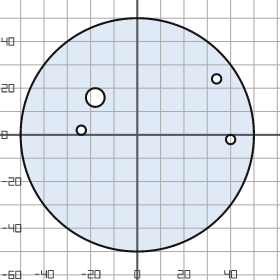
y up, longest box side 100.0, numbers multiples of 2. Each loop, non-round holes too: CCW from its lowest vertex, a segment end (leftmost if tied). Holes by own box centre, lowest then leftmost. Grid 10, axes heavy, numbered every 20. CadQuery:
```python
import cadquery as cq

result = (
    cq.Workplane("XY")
    .moveTo(0.0, 0.0)
    .circle(50.0)
    .moveTo(40.0, -2.0)
    .circle(2.0)
    .moveTo(-24.0, 2.0)
    .circle(2.0)
    .moveTo(-18.0, 16.0)
    .circle(4.0)
    .moveTo(34.0, 24.0)
    .circle(2.0)
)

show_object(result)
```